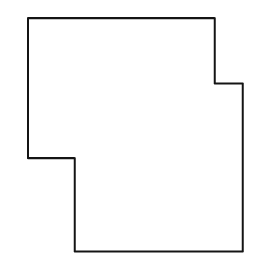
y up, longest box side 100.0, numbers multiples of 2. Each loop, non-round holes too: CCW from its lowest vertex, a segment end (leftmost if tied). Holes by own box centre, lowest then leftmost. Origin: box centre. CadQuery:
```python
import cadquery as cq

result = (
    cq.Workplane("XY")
    .moveTo(-26.0, -50.0)
    .lineTo(46.0, -50.0)
    .lineTo(46.0, 22.0)
    .lineTo(34.0, 22.0)
    .lineTo(34.0, 50.0)
    .lineTo(-46.0, 50.0)
    .lineTo(-46.0, -10.0)
    .lineTo(-26.0, -10.0)
    .close()
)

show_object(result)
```